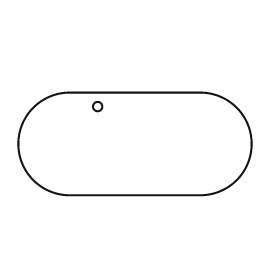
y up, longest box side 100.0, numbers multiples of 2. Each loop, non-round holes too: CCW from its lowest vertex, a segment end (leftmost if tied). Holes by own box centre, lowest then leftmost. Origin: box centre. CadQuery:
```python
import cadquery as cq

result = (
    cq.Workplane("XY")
    .moveTo(-28.0, -22.0)
    .lineTo(28.0, -22.0)
    .threePointArc((50.0, 0.0), (28.0, 22.0))
    .lineTo(-28.0, 22.0)
    .threePointArc((-50.0, 0.0), (-28.0, -22.0))
    .close()
    .moveTo(-16.0, 16.0)
    .circle(2.0)
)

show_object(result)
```